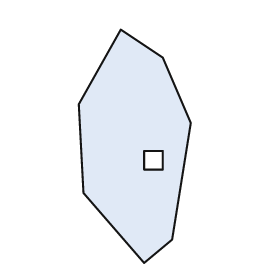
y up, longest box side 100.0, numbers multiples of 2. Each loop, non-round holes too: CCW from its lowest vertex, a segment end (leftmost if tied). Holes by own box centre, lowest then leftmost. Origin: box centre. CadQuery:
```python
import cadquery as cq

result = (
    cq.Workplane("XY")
    .moveTo(4.0, -50.0)
    .lineTo(16.0, -40.0)
    .lineTo(24.0, 10.0)
    .lineTo(12.0, 38.0)
    .lineTo(-6.0, 50.0)
    .lineTo(-24.0, 18.0)
    .lineTo(-22.0, -20.0)
    .close()
    .moveTo(4.0, -10.0)
    .lineTo(12.0, -10.0)
    .lineTo(12.0, -2.0)
    .lineTo(4.0, -2.0)
    .close()
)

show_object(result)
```